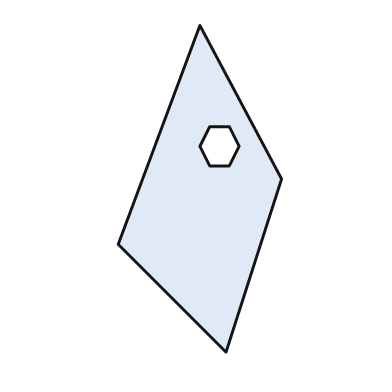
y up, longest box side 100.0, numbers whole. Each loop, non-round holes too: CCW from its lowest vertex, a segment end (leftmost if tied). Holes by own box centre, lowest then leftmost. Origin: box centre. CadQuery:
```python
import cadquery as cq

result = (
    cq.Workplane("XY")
    .moveTo(8.0, -50.0)
    .lineTo(25.0, 3.0)
    .lineTo(0.0, 50.0)
    .lineTo(-25.0, -17.0)
    .close()
    .moveTo(3.0, 7.0)
    .lineTo(9.0, 7.0)
    .lineTo(12.0, 13.0)
    .lineTo(9.0, 19.0)
    .lineTo(3.0, 19.0)
    .lineTo(0.0, 13.0)
    .close()
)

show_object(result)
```